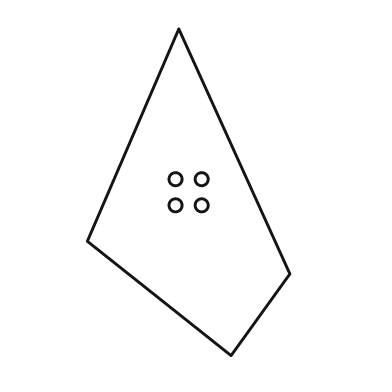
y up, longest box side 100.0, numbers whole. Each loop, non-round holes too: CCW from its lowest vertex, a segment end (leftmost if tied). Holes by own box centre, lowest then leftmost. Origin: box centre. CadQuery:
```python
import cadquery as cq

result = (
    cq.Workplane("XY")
    .moveTo(13.0, -50.0)
    .lineTo(31.0, -25.0)
    .lineTo(-3.0, 50.0)
    .lineTo(-31.0, -15.0)
    .close()
    .moveTo(-4.0, -4.0)
    .circle(2.0)
    .moveTo(4.0, -4.0)
    .circle(2.0)
    .moveTo(-4.0, 4.0)
    .circle(2.0)
    .moveTo(4.0, 4.0)
    .circle(2.0)
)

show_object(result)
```